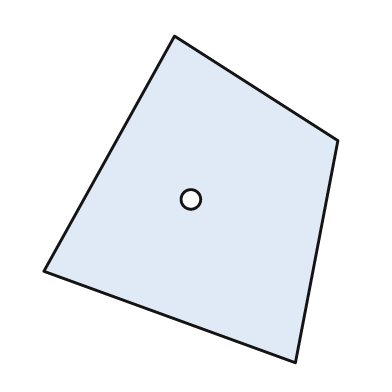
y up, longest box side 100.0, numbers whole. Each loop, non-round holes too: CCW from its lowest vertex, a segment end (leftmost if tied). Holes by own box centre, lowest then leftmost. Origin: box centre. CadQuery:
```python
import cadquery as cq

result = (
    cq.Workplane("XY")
    .moveTo(32.0, -50.0)
    .lineTo(45.0, 18.0)
    .lineTo(-5.0, 50.0)
    .lineTo(-45.0, -22.0)
    .close()
    .moveTo(0.0, 0.0)
    .circle(3.0)
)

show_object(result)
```